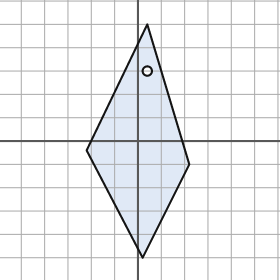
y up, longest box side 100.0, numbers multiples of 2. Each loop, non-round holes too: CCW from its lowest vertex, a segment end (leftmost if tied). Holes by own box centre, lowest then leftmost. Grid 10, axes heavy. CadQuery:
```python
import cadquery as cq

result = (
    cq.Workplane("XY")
    .moveTo(2.0, -50.0)
    .lineTo(22.0, -10.0)
    .lineTo(4.0, 50.0)
    .lineTo(-22.0, -4.0)
    .close()
    .moveTo(4.0, 30.0)
    .circle(2.0)
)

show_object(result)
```